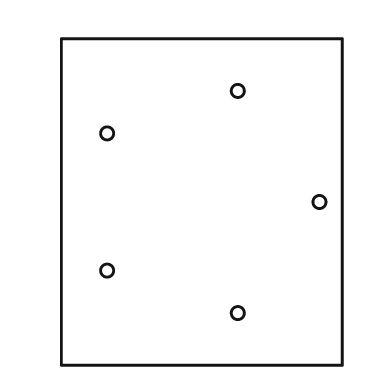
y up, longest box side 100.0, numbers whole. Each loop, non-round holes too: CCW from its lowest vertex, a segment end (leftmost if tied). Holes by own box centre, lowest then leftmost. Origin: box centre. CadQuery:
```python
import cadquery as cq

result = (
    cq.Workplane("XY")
    .moveTo(-43.0, -50.0)
    .lineTo(43.0, -50.0)
    .lineTo(43.0, 50.0)
    .lineTo(-43.0, 50.0)
    .close()
    .moveTo(11.0, -34.0)
    .circle(2.0)
    .moveTo(-29.0, -21.0)
    .circle(2.0)
    .moveTo(36.0, 0.0)
    .circle(2.0)
    .moveTo(-29.0, 21.0)
    .circle(2.0)
    .moveTo(11.0, 34.0)
    .circle(2.0)
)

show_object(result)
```